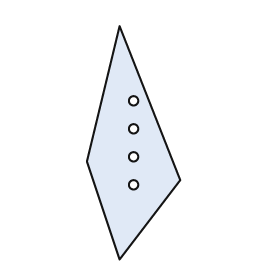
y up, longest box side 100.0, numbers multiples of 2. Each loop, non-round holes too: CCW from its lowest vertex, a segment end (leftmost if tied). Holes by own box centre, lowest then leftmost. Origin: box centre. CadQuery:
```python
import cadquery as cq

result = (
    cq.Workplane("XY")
    .moveTo(-6.0, -50.0)
    .lineTo(20.0, -16.0)
    .lineTo(-6.0, 50.0)
    .lineTo(-20.0, -8.0)
    .close()
    .moveTo(0.0, -18.0)
    .circle(2.0)
    .moveTo(0.0, -6.0)
    .circle(2.0)
    .moveTo(0.0, 6.0)
    .circle(2.0)
    .moveTo(0.0, 18.0)
    .circle(2.0)
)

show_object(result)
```